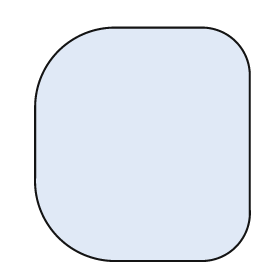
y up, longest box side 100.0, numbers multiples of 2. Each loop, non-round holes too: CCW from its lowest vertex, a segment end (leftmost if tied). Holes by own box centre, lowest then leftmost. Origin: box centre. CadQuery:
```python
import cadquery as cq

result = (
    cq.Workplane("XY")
    .moveTo(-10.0, -50.0)
    .lineTo(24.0, -50.0)
    .threePointArc((40.0, -44.0), (46.0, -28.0))
    .lineTo(46.0, 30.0)
    .threePointArc((40.0, 44.0), (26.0, 50.0))
    .lineTo(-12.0, 50.0)
    .threePointArc((-36.0, 40.0), (-46.0, 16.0))
    .lineTo(-46.0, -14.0)
    .threePointArc((-36.0, -40.0), (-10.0, -50.0))
    .close()
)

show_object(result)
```